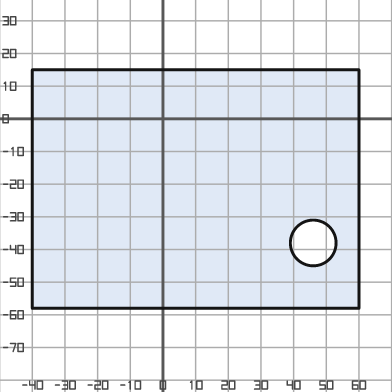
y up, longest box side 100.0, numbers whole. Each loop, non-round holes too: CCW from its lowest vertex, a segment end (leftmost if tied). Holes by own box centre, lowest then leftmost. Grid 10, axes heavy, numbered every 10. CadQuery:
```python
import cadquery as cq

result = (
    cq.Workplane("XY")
    .moveTo(-40.0, -58.0)
    .lineTo(60.0, -58.0)
    .lineTo(60.0, 15.0)
    .lineTo(-40.0, 15.0)
    .close()
    .moveTo(46.0, -38.0)
    .circle(7.0)
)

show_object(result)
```